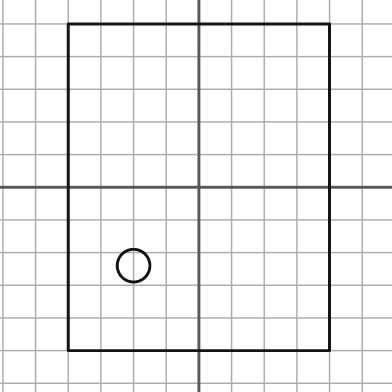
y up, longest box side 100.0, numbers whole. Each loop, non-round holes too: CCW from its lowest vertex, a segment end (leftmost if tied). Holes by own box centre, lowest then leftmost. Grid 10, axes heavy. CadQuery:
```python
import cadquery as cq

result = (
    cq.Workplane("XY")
    .moveTo(-40.0, -50.0)
    .lineTo(40.0, -50.0)
    .lineTo(40.0, 50.0)
    .lineTo(-40.0, 50.0)
    .close()
    .moveTo(-20.0, -24.0)
    .circle(5.0)
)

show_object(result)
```